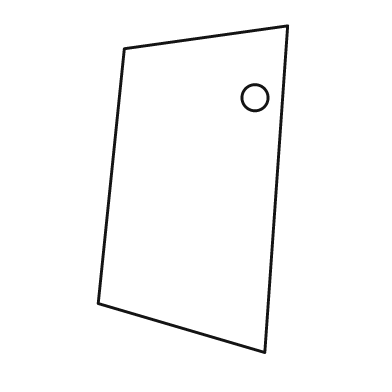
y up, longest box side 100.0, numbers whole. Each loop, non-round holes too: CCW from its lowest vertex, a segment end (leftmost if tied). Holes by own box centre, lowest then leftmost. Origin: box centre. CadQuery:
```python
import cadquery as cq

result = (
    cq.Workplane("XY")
    .moveTo(22.0, -50.0)
    .lineTo(29.0, 50.0)
    .lineTo(-21.0, 43.0)
    .lineTo(-29.0, -35.0)
    .close()
    .moveTo(19.0, 28.0)
    .circle(4.0)
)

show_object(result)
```